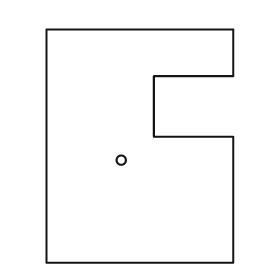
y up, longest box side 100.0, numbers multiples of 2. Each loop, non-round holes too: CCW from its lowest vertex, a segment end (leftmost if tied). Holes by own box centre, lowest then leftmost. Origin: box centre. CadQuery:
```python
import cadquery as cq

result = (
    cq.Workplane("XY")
    .moveTo(-40.0, -50.0)
    .lineTo(40.0, -50.0)
    .lineTo(40.0, 4.0)
    .lineTo(6.0, 4.0)
    .lineTo(6.0, 30.0)
    .lineTo(40.0, 30.0)
    .lineTo(40.0, 50.0)
    .lineTo(-40.0, 50.0)
    .close()
    .moveTo(-8.0, -6.0)
    .circle(2.0)
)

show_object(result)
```